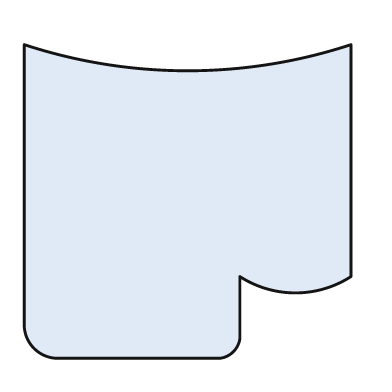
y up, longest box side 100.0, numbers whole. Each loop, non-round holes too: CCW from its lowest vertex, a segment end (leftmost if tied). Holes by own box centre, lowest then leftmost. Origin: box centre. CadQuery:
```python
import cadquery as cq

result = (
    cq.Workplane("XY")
    .moveTo(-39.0, -48.0)
    .lineTo(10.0, -48.0)
    .threePointArc((14.0, -46.0), (16.0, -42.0))
    .lineTo(16.0, -23.0)
    .threePointArc((33.0, -28.0), (50.0, -23.0))
    .lineTo(50.0, 48.0)
    .threePointArc((0.0, 40.0), (-50.0, 48.0))
    .lineTo(-50.0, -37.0)
    .threePointArc((-47.0, -45.0), (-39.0, -48.0))
    .close()
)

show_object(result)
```